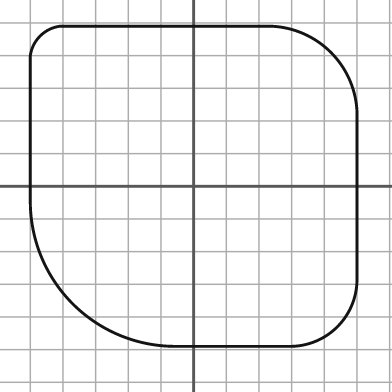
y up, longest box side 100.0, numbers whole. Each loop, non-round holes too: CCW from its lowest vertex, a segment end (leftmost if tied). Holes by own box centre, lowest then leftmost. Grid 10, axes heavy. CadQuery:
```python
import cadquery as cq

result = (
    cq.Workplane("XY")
    .moveTo(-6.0, -49.0)
    .lineTo(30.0, -49.0)
    .threePointArc((44.0, -43.0), (50.0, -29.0))
    .lineTo(50.0, 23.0)
    .threePointArc((42.0, 41.0), (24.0, 49.0))
    .lineTo(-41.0, 49.0)
    .threePointArc((-47.0, 46.0), (-50.0, 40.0))
    .lineTo(-50.0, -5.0)
    .threePointArc((-37.0, -36.0), (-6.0, -49.0))
    .close()
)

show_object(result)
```